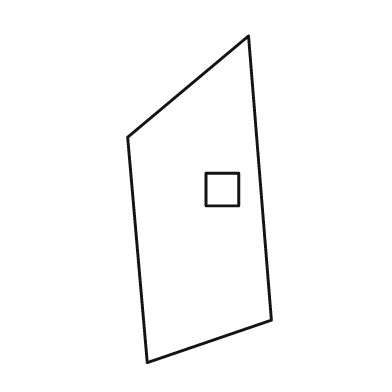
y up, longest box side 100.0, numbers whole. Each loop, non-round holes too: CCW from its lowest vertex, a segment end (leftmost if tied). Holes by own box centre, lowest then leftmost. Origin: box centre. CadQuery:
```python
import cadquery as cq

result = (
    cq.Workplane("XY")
    .moveTo(-16.0, -50.0)
    .lineTo(22.0, -37.0)
    .lineTo(15.0, 50.0)
    .lineTo(-22.0, 19.0)
    .close()
    .moveTo(2.0, -2.0)
    .lineTo(12.0, -2.0)
    .lineTo(12.0, 8.0)
    .lineTo(2.0, 8.0)
    .close()
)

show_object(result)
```